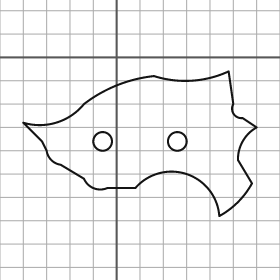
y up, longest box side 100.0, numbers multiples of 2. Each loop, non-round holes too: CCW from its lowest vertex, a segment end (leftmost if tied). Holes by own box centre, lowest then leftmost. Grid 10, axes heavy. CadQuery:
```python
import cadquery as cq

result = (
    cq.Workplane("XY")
    .moveTo(44.0, -68.0)
    .threePointArc((52.0, -62.0), (58.0, -54.0))
    .lineTo(52.0, -44.0)
    .threePointArc((54.0, -36.0), (60.0, -30.0))
    .lineTo(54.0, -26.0)
    .threePointArc((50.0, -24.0), (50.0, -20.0))
    .lineTo(48.0, -6.0)
    .threePointArc((32.0, -10.0), (16.0, -8.0))
    .threePointArc((0.0, -12.0), (-14.0, -20.0))
    .threePointArc((-26.0, -28.0), (-40.0, -28.0))
    .lineTo(-32.0, -36.0)
    .lineTo(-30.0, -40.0)
    .threePointArc((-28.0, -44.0), (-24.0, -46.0))
    .lineTo(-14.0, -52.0)
    .threePointArc((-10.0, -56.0), (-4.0, -56.0))
    .lineTo(8.0, -56.0)
    .threePointArc((30.0, -50.0), (44.0, -68.0))
    .close()
    .moveTo(-6.0, -36.0)
    .circle(4.0)
    .moveTo(26.0, -36.0)
    .circle(4.0)
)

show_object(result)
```